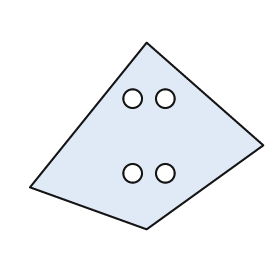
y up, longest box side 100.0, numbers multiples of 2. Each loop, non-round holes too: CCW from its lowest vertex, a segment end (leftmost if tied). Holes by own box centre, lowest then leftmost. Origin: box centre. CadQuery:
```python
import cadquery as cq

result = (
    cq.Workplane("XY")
    .moveTo(0.0, -40.0)
    .lineTo(50.0, -4.0)
    .lineTo(0.0, 40.0)
    .lineTo(-50.0, -22.0)
    .close()
    .moveTo(-6.0, -16.0)
    .circle(4.0)
    .moveTo(8.0, -16.0)
    .circle(4.0)
    .moveTo(-6.0, 16.0)
    .circle(4.0)
    .moveTo(8.0, 16.0)
    .circle(4.0)
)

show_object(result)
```